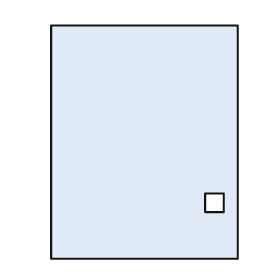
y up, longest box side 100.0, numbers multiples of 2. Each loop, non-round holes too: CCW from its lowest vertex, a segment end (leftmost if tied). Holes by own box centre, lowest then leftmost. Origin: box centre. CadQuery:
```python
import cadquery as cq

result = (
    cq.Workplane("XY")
    .moveTo(-40.0, -50.0)
    .lineTo(40.0, -50.0)
    .lineTo(40.0, 50.0)
    .lineTo(-40.0, 50.0)
    .close()
    .moveTo(26.0, -30.0)
    .lineTo(34.0, -30.0)
    .lineTo(34.0, -22.0)
    .lineTo(26.0, -22.0)
    .close()
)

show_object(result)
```